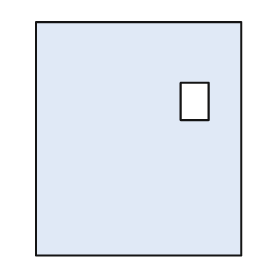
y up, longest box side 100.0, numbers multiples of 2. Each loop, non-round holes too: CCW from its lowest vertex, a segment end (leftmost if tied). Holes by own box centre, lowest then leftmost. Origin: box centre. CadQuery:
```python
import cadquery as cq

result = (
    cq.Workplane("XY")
    .moveTo(-44.0, -50.0)
    .lineTo(44.0, -50.0)
    .lineTo(44.0, 50.0)
    .lineTo(-44.0, 50.0)
    .close()
    .moveTo(18.0, 8.0)
    .lineTo(30.0, 8.0)
    .lineTo(30.0, 24.0)
    .lineTo(18.0, 24.0)
    .close()
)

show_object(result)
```